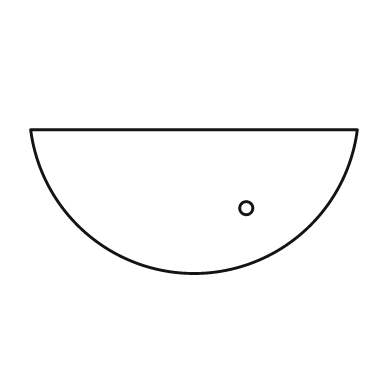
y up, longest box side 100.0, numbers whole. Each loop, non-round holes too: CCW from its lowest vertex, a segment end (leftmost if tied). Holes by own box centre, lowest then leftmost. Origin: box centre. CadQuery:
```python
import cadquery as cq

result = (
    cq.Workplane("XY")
    .moveTo(-50.0, 22.0)
    .threePointArc((0.0, -22.0), (50.0, 22.0))
    .close()
    .moveTo(16.0, -2.0)
    .circle(2.0)
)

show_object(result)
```